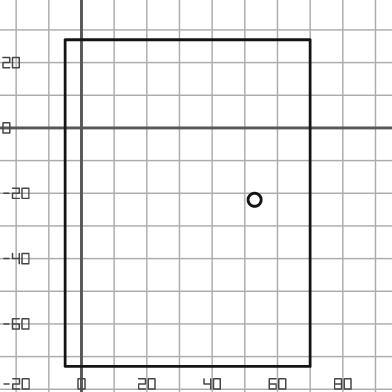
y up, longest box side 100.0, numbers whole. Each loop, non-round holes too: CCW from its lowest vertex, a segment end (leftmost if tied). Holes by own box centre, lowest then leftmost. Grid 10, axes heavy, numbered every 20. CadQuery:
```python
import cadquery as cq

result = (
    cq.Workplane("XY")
    .moveTo(-5.0, -73.0)
    .lineTo(70.0, -73.0)
    .lineTo(70.0, 27.0)
    .lineTo(-5.0, 27.0)
    .close()
    .moveTo(53.0, -22.0)
    .circle(2.0)
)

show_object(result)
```